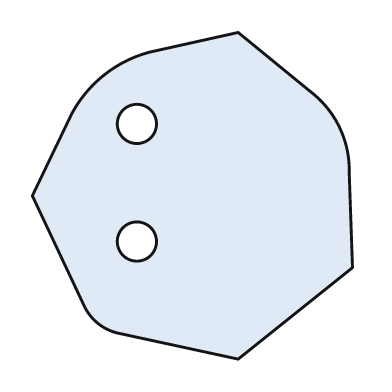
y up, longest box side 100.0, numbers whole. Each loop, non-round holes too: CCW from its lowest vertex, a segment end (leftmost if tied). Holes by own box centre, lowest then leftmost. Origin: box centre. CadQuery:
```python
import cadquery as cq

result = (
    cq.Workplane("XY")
    .moveTo(14.0, -50.0)
    .lineTo(49.0, -22.0)
    .lineTo(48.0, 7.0)
    .threePointArc((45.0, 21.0), (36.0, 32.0))
    .lineTo(14.0, 50.0)
    .lineTo(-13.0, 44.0)
    .threePointArc((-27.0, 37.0), (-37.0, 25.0))
    .lineTo(-49.0, 0.0)
    .lineTo(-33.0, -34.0)
    .threePointArc((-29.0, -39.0), (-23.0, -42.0))
    .close()
    .moveTo(-17.0, -14.0)
    .circle(6.0)
    .moveTo(-17.0, 22.0)
    .circle(6.0)
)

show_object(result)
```